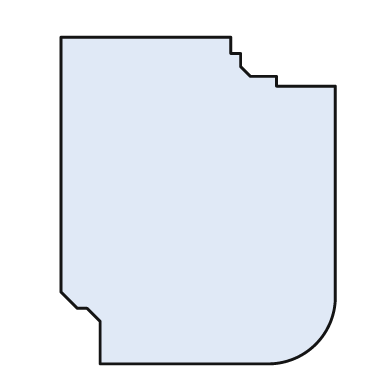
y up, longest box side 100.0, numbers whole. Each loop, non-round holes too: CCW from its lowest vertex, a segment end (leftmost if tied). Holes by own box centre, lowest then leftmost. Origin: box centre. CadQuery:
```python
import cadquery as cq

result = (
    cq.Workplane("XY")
    .moveTo(-30.0, -50.0)
    .lineTo(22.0, -50.0)
    .threePointArc((36.0, -44.0), (42.0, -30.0))
    .lineTo(42.0, 35.0)
    .lineTo(24.0, 35.0)
    .lineTo(24.0, 38.0)
    .lineTo(16.0, 38.0)
    .lineTo(13.0, 41.0)
    .lineTo(13.0, 45.0)
    .lineTo(10.0, 45.0)
    .lineTo(10.0, 50.0)
    .lineTo(-42.0, 50.0)
    .lineTo(-42.0, -28.0)
    .lineTo(-37.0, -33.0)
    .lineTo(-34.0, -33.0)
    .lineTo(-30.0, -37.0)
    .close()
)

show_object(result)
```